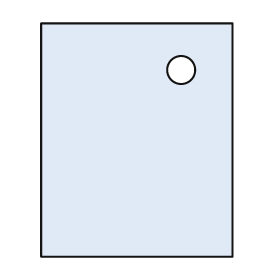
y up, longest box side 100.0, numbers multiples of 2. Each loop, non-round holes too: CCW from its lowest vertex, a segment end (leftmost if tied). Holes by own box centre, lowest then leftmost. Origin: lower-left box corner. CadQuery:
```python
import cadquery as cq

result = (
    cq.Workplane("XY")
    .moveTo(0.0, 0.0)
    .lineTo(82.0, 0.0)
    .lineTo(82.0, 100.0)
    .lineTo(0.0, 100.0)
    .close()
    .moveTo(60.0, 80.0)
    .circle(6.0)
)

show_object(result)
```